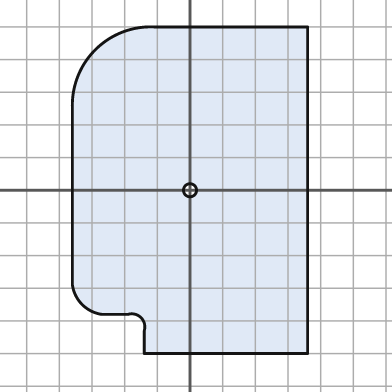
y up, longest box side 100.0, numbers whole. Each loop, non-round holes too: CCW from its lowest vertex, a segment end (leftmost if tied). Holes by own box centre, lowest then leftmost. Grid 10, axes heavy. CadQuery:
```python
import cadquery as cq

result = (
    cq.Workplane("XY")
    .moveTo(-14.0, -50.0)
    .lineTo(36.0, -50.0)
    .lineTo(36.0, 50.0)
    .lineTo(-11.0, 50.0)
    .threePointArc((-29.0, 43.0), (-36.0, 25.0))
    .lineTo(-36.0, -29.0)
    .threePointArc((-33.0, -35.0), (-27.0, -38.0))
    .lineTo(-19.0, -38.0)
    .threePointArc((-15.0, -39.0), (-14.0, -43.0))
    .close()
    .moveTo(0.0, 0.0)
    .circle(2.0)
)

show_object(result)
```